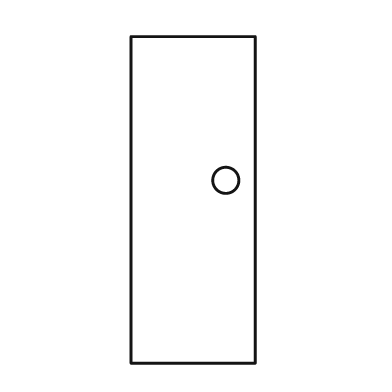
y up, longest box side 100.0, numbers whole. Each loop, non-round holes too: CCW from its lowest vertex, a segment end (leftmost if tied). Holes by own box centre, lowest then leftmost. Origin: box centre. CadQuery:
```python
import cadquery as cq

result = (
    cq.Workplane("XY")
    .moveTo(-19.0, -50.0)
    .lineTo(19.0, -50.0)
    .lineTo(19.0, 50.0)
    .lineTo(-19.0, 50.0)
    .close()
    .moveTo(10.0, 6.0)
    .circle(4.0)
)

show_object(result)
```